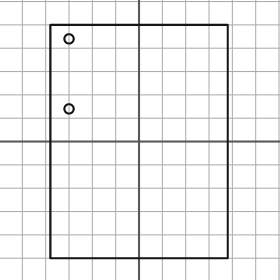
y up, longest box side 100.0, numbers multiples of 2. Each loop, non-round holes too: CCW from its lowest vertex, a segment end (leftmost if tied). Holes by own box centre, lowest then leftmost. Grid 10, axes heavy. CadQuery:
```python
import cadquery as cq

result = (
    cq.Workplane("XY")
    .moveTo(-38.0, -50.0)
    .lineTo(38.0, -50.0)
    .lineTo(38.0, 50.0)
    .lineTo(-38.0, 50.0)
    .close()
    .moveTo(-30.0, 14.0)
    .circle(2.0)
    .moveTo(-30.0, 44.0)
    .circle(2.0)
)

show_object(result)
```